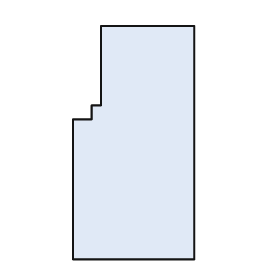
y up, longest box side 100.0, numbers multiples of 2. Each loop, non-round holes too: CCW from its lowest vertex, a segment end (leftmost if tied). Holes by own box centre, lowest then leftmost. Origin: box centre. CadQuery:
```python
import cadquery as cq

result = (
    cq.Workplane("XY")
    .moveTo(-26.0, -50.0)
    .lineTo(26.0, -50.0)
    .lineTo(26.0, 50.0)
    .lineTo(-14.0, 50.0)
    .lineTo(-14.0, 16.0)
    .lineTo(-18.0, 16.0)
    .lineTo(-18.0, 10.0)
    .lineTo(-26.0, 10.0)
    .close()
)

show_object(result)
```